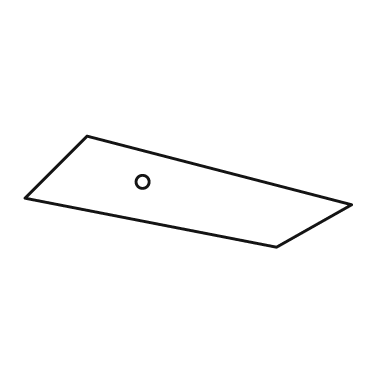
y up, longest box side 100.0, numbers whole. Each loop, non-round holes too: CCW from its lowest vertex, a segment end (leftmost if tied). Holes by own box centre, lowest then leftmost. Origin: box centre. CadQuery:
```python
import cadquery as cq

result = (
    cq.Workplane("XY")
    .moveTo(27.0, -17.0)
    .lineTo(50.0, -4.0)
    .lineTo(-31.0, 17.0)
    .lineTo(-50.0, -2.0)
    .close()
    .moveTo(-14.0, 3.0)
    .circle(2.0)
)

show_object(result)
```